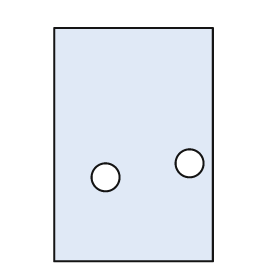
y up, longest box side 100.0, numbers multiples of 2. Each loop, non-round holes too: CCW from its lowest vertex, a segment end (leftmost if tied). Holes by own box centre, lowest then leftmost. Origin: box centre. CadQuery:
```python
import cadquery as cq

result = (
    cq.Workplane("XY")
    .moveTo(-34.0, -50.0)
    .lineTo(34.0, -50.0)
    .lineTo(34.0, 50.0)
    .lineTo(-34.0, 50.0)
    .close()
    .moveTo(-12.0, -14.0)
    .circle(6.0)
    .moveTo(24.0, -8.0)
    .circle(6.0)
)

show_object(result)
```